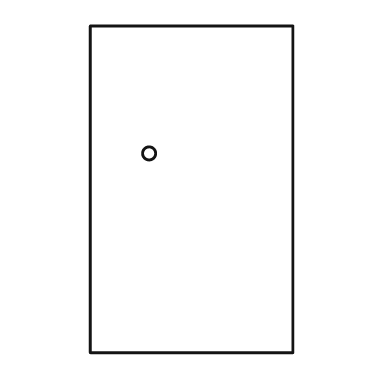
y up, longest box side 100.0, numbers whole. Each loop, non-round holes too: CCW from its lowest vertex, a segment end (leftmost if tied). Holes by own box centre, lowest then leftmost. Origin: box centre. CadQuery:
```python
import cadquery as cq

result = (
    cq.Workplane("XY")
    .moveTo(-31.0, -50.0)
    .lineTo(31.0, -50.0)
    .lineTo(31.0, 50.0)
    .lineTo(-31.0, 50.0)
    .close()
    .moveTo(-13.0, 11.0)
    .circle(2.0)
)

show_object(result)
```